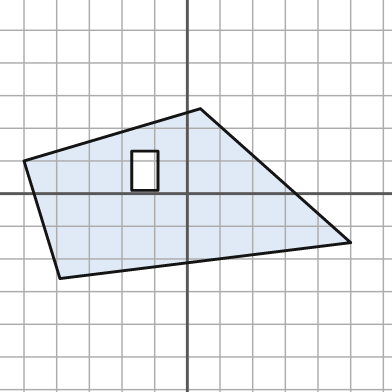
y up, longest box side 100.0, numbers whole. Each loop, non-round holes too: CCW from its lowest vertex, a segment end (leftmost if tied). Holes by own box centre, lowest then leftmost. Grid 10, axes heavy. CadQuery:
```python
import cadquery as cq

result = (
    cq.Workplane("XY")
    .moveTo(-39.0, -26.0)
    .lineTo(50.0, -15.0)
    .lineTo(4.0, 26.0)
    .lineTo(-50.0, 10.0)
    .close()
    .moveTo(-17.0, 1.0)
    .lineTo(-9.0, 1.0)
    .lineTo(-9.0, 13.0)
    .lineTo(-17.0, 13.0)
    .close()
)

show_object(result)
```